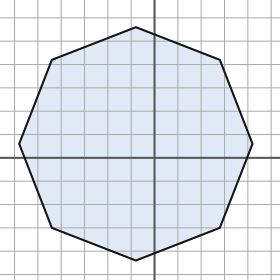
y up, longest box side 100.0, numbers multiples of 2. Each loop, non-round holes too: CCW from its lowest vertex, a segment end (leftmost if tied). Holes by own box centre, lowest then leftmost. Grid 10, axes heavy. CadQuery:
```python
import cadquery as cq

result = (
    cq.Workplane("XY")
    .moveTo(-8.0, -44.0)
    .lineTo(28.0, -30.0)
    .lineTo(42.0, 6.0)
    .lineTo(28.0, 42.0)
    .lineTo(-8.0, 56.0)
    .lineTo(-44.0, 42.0)
    .lineTo(-58.0, 6.0)
    .lineTo(-44.0, -30.0)
    .close()
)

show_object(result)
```